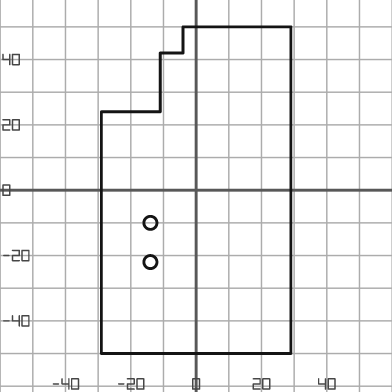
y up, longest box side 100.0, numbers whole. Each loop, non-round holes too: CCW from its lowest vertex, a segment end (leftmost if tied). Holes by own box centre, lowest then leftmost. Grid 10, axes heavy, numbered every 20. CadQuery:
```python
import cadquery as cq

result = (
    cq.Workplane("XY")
    .moveTo(-29.0, -50.0)
    .lineTo(29.0, -50.0)
    .lineTo(29.0, 50.0)
    .lineTo(-4.0, 50.0)
    .lineTo(-4.0, 42.0)
    .lineTo(-11.0, 42.0)
    .lineTo(-11.0, 24.0)
    .lineTo(-29.0, 24.0)
    .close()
    .moveTo(-14.0, -22.0)
    .circle(2.0)
    .moveTo(-14.0, -10.0)
    .circle(2.0)
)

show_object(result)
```